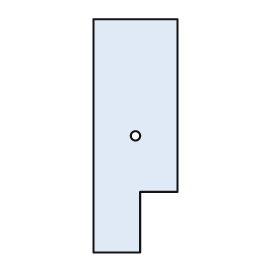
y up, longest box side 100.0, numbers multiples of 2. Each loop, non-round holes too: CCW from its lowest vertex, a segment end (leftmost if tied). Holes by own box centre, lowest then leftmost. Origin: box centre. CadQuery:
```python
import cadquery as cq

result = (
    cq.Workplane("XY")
    .moveTo(-18.0, -50.0)
    .lineTo(2.0, -50.0)
    .lineTo(2.0, -24.0)
    .lineTo(18.0, -24.0)
    .lineTo(18.0, 50.0)
    .lineTo(-18.0, 50.0)
    .close()
    .moveTo(0.0, 0.0)
    .circle(2.0)
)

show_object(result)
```